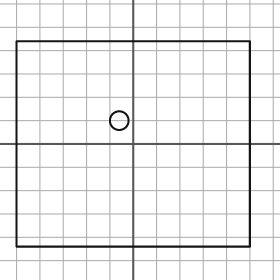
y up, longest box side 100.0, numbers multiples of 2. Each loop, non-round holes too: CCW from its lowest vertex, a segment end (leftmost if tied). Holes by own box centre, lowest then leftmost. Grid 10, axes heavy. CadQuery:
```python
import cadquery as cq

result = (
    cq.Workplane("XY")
    .moveTo(-50.0, -44.0)
    .lineTo(50.0, -44.0)
    .lineTo(50.0, 44.0)
    .lineTo(-50.0, 44.0)
    .close()
    .moveTo(-6.0, 10.0)
    .circle(4.0)
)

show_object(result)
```